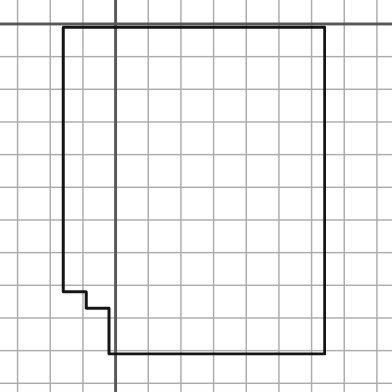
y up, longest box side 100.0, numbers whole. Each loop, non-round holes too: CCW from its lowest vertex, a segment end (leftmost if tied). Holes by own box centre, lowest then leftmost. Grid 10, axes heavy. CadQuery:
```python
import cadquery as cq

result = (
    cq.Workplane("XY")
    .moveTo(-2.0, -101.0)
    .lineTo(64.0, -101.0)
    .lineTo(64.0, -1.0)
    .lineTo(-16.0, -1.0)
    .lineTo(-16.0, -82.0)
    .lineTo(-9.0, -82.0)
    .lineTo(-9.0, -87.0)
    .lineTo(-2.0, -87.0)
    .close()
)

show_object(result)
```